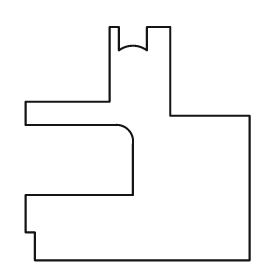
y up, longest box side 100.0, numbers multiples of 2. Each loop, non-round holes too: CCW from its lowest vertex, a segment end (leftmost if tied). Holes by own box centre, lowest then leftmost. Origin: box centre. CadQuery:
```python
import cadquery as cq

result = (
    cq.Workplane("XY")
    .moveTo(-44.0, -50.0)
    .lineTo(48.0, -50.0)
    .lineTo(48.0, 12.0)
    .lineTo(14.0, 12.0)
    .lineTo(14.0, 50.0)
    .lineTo(4.0, 50.0)
    .lineTo(4.0, 40.0)
    .threePointArc((-2.0, 42.0), (-8.0, 40.0))
    .lineTo(-8.0, 50.0)
    .lineTo(-12.0, 50.0)
    .lineTo(-12.0, 18.0)
    .lineTo(-48.0, 18.0)
    .lineTo(-48.0, 8.0)
    .lineTo(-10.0, 8.0)
    .threePointArc((-4.0, 6.0), (-2.0, 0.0))
    .lineTo(-2.0, -22.0)
    .lineTo(-48.0, -22.0)
    .lineTo(-48.0, -38.0)
    .lineTo(-44.0, -38.0)
    .close()
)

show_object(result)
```